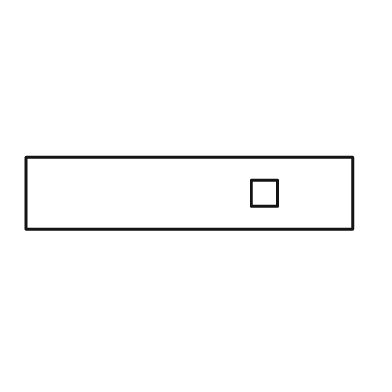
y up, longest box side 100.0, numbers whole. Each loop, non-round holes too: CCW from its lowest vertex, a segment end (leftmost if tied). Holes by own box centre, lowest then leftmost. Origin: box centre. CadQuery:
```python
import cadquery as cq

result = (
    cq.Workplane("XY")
    .moveTo(-50.0, -11.0)
    .lineTo(50.0, -11.0)
    .lineTo(50.0, 11.0)
    .lineTo(-50.0, 11.0)
    .close()
    .moveTo(19.0, -4.0)
    .lineTo(27.0, -4.0)
    .lineTo(27.0, 4.0)
    .lineTo(19.0, 4.0)
    .close()
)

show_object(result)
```